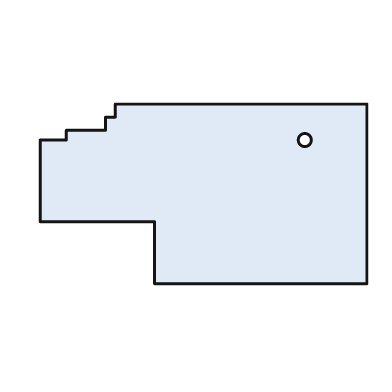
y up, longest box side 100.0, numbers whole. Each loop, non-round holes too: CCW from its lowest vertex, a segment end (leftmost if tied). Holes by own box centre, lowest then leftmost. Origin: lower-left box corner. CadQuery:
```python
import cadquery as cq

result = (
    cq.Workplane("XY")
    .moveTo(35.0, 0.0)
    .lineTo(100.0, 0.0)
    .lineTo(100.0, 55.0)
    .lineTo(23.0, 55.0)
    .lineTo(23.0, 51.0)
    .lineTo(20.0, 51.0)
    .lineTo(20.0, 47.0)
    .lineTo(8.0, 47.0)
    .lineTo(8.0, 44.0)
    .lineTo(0.0, 44.0)
    .lineTo(0.0, 19.0)
    .lineTo(35.0, 19.0)
    .close()
    .moveTo(81.0, 44.0)
    .circle(2.0)
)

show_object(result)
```